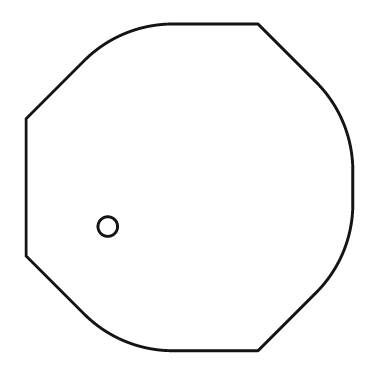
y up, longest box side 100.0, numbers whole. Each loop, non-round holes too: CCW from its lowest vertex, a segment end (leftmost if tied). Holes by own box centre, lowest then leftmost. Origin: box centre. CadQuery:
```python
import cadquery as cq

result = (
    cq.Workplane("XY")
    .moveTo(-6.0, -50.0)
    .lineTo(21.0, -50.0)
    .lineTo(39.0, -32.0)
    .threePointArc((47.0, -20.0), (50.0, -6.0))
    .lineTo(50.0, 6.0)
    .threePointArc((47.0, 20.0), (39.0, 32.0))
    .lineTo(21.0, 50.0)
    .lineTo(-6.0, 50.0)
    .threePointArc((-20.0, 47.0), (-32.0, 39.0))
    .lineTo(-50.0, 21.0)
    .lineTo(-50.0, -21.0)
    .lineTo(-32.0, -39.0)
    .threePointArc((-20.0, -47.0), (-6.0, -50.0))
    .close()
    .moveTo(-25.0, -12.0)
    .circle(3.0)
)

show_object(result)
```